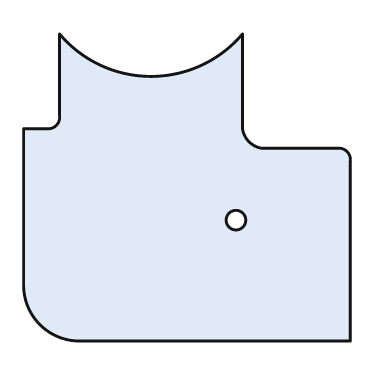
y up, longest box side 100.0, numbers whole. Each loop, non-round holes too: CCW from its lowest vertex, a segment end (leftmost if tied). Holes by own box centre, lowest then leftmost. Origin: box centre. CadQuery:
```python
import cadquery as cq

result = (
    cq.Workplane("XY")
    .moveTo(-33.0, -47.0)
    .lineTo(50.0, -47.0)
    .lineTo(50.0, 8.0)
    .threePointArc((49.0, 11.0), (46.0, 12.0))
    .lineTo(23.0, 12.0)
    .threePointArc((19.0, 14.0), (17.0, 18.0))
    .lineTo(17.0, 47.0)
    .threePointArc((-11.0, 34.0), (-39.0, 47.0))
    .lineTo(-39.0, 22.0)
    .threePointArc((-40.0, 19.0), (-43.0, 18.0))
    .lineTo(-50.0, 18.0)
    .lineTo(-50.0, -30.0)
    .threePointArc((-45.0, -42.0), (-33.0, -47.0))
    .close()
    .moveTo(15.0, -10.0)
    .circle(3.0)
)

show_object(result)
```